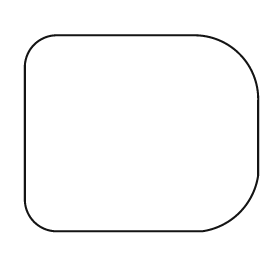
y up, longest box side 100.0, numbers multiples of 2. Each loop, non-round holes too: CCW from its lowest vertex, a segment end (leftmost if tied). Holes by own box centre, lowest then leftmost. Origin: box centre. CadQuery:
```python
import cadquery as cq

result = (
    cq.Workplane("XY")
    .moveTo(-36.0, -42.0)
    .lineTo(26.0, -42.0)
    .threePointArc((42.0, -34.0), (50.0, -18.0))
    .lineTo(50.0, 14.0)
    .threePointArc((42.0, 34.0), (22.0, 42.0))
    .lineTo(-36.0, 42.0)
    .threePointArc((-46.0, 38.0), (-50.0, 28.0))
    .lineTo(-50.0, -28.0)
    .threePointArc((-46.0, -38.0), (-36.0, -42.0))
    .close()
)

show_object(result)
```